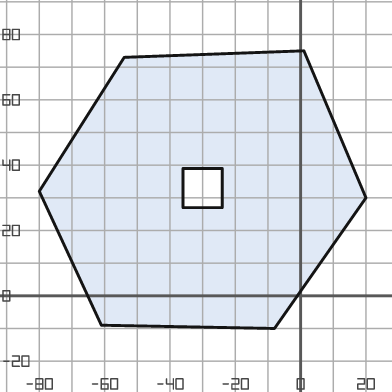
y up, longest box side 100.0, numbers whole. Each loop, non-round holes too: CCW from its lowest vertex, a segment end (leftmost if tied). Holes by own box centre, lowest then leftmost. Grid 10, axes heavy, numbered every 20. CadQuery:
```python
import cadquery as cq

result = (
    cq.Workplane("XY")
    .moveTo(-8.0, -10.0)
    .lineTo(20.0, 30.0)
    .lineTo(1.0, 75.0)
    .lineTo(-54.0, 73.0)
    .lineTo(-80.0, 32.0)
    .lineTo(-61.0, -9.0)
    .close()
    .moveTo(-36.0, 27.0)
    .lineTo(-24.0, 27.0)
    .lineTo(-24.0, 39.0)
    .lineTo(-36.0, 39.0)
    .close()
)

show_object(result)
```